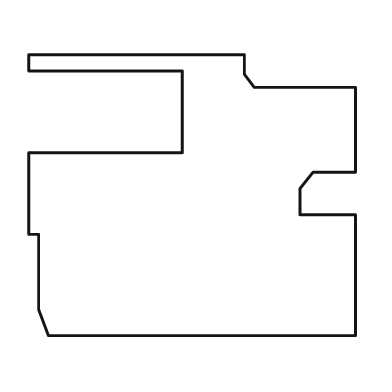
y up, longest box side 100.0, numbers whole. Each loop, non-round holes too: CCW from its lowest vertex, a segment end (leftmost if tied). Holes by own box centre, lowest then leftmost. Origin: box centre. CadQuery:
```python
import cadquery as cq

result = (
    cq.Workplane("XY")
    .moveTo(-44.0, -43.0)
    .lineTo(50.0, -43.0)
    .lineTo(50.0, -6.0)
    .lineTo(33.0, -6.0)
    .lineTo(33.0, 2.0)
    .lineTo(37.0, 7.0)
    .lineTo(50.0, 7.0)
    .lineTo(50.0, 33.0)
    .lineTo(19.0, 33.0)
    .lineTo(16.0, 37.0)
    .lineTo(16.0, 43.0)
    .lineTo(-50.0, 43.0)
    .lineTo(-50.0, 38.0)
    .lineTo(-3.0, 38.0)
    .lineTo(-3.0, 13.0)
    .lineTo(-50.0, 13.0)
    .lineTo(-50.0, -12.0)
    .lineTo(-47.0, -12.0)
    .lineTo(-47.0, -35.0)
    .close()
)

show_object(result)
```